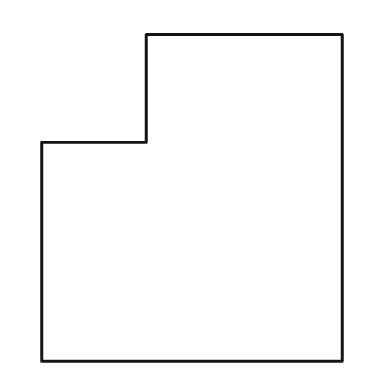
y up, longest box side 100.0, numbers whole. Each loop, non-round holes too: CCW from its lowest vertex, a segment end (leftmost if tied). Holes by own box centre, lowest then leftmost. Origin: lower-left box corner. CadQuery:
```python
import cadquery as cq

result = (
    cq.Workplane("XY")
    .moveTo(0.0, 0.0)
    .lineTo(92.0, 0.0)
    .lineTo(92.0, 100.0)
    .lineTo(32.0, 100.0)
    .lineTo(32.0, 67.0)
    .lineTo(0.0, 67.0)
    .close()
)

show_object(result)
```